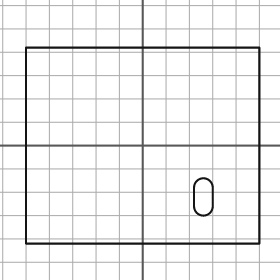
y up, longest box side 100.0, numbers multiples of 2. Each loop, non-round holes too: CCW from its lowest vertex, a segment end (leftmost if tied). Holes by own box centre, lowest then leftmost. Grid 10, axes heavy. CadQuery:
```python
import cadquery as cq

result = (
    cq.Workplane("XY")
    .moveTo(-50.0, -42.0)
    .lineTo(50.0, -42.0)
    .lineTo(50.0, 42.0)
    .lineTo(-50.0, 42.0)
    .close()
    .moveTo(22.0, -26.0)
    .threePointArc((26.0, -30.0), (30.0, -26.0))
    .lineTo(30.0, -18.0)
    .threePointArc((26.0, -14.0), (22.0, -18.0))
    .close()
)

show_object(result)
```